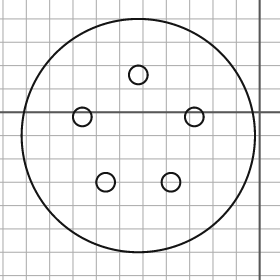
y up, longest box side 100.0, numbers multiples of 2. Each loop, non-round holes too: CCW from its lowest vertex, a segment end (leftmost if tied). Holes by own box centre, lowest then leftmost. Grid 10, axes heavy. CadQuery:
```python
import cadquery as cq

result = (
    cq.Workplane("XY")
    .moveTo(-52.0, -10.0)
    .circle(50.0)
    .moveTo(-66.0, -30.0)
    .circle(4.0)
    .moveTo(-38.0, -30.0)
    .circle(4.0)
    .moveTo(-76.0, -2.0)
    .circle(4.0)
    .moveTo(-28.0, -2.0)
    .circle(4.0)
    .moveTo(-52.0, 16.0)
    .circle(4.0)
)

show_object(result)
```